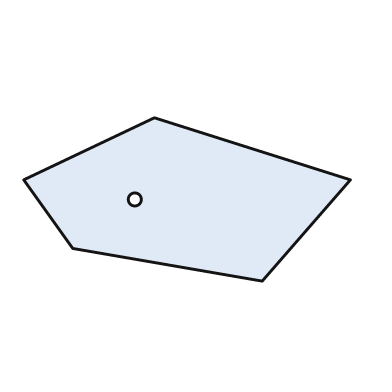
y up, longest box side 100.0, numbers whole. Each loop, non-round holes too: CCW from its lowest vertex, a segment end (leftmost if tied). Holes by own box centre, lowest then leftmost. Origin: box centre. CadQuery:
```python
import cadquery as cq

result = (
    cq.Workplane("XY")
    .moveTo(23.0, -25.0)
    .lineTo(50.0, 6.0)
    .lineTo(-10.0, 25.0)
    .lineTo(-50.0, 6.0)
    .lineTo(-35.0, -15.0)
    .close()
    .moveTo(-16.0, 0.0)
    .circle(2.0)
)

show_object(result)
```